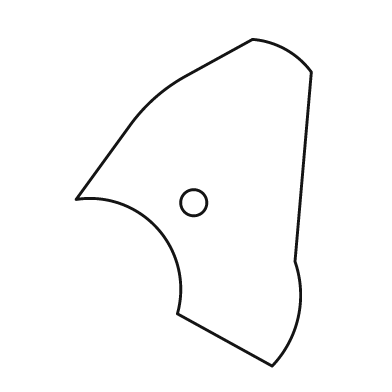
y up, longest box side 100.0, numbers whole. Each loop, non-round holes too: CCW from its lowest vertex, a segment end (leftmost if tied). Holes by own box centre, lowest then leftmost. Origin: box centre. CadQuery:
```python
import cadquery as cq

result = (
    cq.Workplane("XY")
    .moveTo(24.0, -50.0)
    .threePointArc((32.0, -35.0), (31.0, -18.0))
    .lineTo(36.0, 40.0)
    .threePointArc((28.0, 47.0), (18.0, 50.0))
    .lineTo(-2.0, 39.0)
    .threePointArc((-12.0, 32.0), (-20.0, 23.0))
    .lineTo(-36.0, 1.0)
    .threePointArc((-11.0, -8.0), (-5.0, -34.0))
    .close()
    .moveTo(0.0, 0.0)
    .circle(4.0)
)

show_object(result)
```